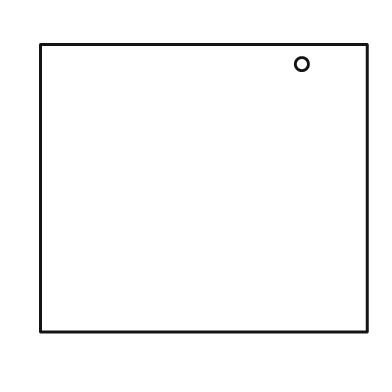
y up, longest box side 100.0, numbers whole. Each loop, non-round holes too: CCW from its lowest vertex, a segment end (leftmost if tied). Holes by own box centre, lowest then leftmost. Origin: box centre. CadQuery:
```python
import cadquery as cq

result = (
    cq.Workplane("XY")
    .moveTo(-50.0, -44.0)
    .lineTo(50.0, -44.0)
    .lineTo(50.0, 44.0)
    .lineTo(-50.0, 44.0)
    .close()
    .moveTo(30.0, 38.0)
    .circle(2.0)
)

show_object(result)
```